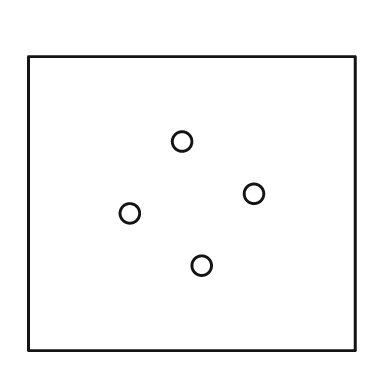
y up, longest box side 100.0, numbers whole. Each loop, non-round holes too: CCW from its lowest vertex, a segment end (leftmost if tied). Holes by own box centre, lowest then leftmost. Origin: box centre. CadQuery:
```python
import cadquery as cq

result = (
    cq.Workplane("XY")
    .moveTo(-50.0, -45.0)
    .lineTo(50.0, -45.0)
    .lineTo(50.0, 45.0)
    .lineTo(-50.0, 45.0)
    .close()
    .moveTo(3.0, -19.0)
    .circle(3.0)
    .moveTo(-19.0, -3.0)
    .circle(3.0)
    .moveTo(19.0, 3.0)
    .circle(3.0)
    .moveTo(-3.0, 19.0)
    .circle(3.0)
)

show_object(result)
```